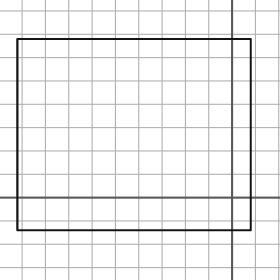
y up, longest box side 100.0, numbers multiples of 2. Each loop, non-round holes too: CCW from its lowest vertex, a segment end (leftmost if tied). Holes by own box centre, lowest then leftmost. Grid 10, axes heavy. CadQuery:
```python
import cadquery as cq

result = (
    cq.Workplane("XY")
    .moveTo(-92.0, -14.0)
    .lineTo(8.0, -14.0)
    .lineTo(8.0, 68.0)
    .lineTo(-92.0, 68.0)
    .close()
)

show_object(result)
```